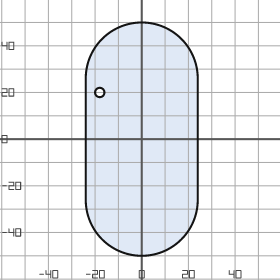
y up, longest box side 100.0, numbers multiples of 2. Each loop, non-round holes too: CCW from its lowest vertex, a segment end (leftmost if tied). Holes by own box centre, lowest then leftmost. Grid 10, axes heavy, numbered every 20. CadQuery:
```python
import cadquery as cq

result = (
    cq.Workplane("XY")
    .moveTo(-24.0, -26.0)
    .threePointArc((0.0, -50.0), (24.0, -26.0))
    .lineTo(24.0, 26.0)
    .threePointArc((0.0, 50.0), (-24.0, 26.0))
    .close()
    .moveTo(-18.0, 20.0)
    .circle(2.0)
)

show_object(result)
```